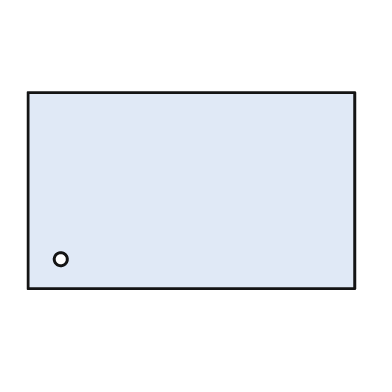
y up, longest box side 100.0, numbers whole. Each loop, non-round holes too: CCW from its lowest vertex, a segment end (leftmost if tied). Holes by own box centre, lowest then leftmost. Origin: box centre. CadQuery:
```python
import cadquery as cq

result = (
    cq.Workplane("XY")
    .moveTo(-50.0, -30.0)
    .lineTo(50.0, -30.0)
    .lineTo(50.0, 30.0)
    .lineTo(-50.0, 30.0)
    .close()
    .moveTo(-40.0, -21.0)
    .circle(2.0)
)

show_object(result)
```